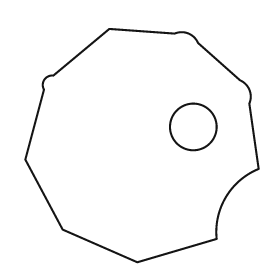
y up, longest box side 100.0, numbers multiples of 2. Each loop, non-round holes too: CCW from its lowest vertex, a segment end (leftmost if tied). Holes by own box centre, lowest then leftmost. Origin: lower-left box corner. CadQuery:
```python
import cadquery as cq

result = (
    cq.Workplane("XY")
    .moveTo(48.0, 0.0)
    .lineTo(82.0, 10.0)
    .threePointArc((86.0, 28.0), (100.0, 40.0))
    .lineTo(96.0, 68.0)
    .threePointArc((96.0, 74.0), (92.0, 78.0))
    .lineTo(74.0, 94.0)
    .threePointArc((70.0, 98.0), (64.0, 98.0))
    .lineTo(36.0, 100.0)
    .lineTo(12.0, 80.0)
    .threePointArc((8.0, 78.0), (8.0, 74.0))
    .lineTo(0.0, 44.0)
    .lineTo(16.0, 14.0)
    .close()
    .moveTo(72.0, 58.0)
    .circle(10.0)
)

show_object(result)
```